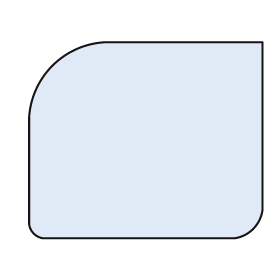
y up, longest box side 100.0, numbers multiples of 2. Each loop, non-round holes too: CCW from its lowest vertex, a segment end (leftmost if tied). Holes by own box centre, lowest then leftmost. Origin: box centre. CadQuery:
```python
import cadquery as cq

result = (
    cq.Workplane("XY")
    .moveTo(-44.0, -42.0)
    .lineTo(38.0, -42.0)
    .threePointArc((46.0, -38.0), (50.0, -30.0))
    .lineTo(50.0, 42.0)
    .lineTo(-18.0, 42.0)
    .threePointArc((-40.0, 32.0), (-50.0, 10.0))
    .lineTo(-50.0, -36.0)
    .threePointArc((-48.0, -40.0), (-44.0, -42.0))
    .close()
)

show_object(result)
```